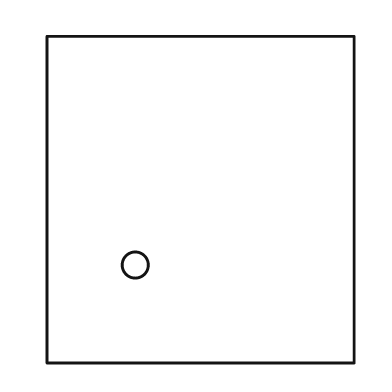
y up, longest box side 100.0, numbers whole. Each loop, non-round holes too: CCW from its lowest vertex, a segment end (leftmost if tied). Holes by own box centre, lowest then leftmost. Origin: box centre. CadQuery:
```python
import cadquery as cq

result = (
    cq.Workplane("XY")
    .moveTo(-47.0, -50.0)
    .lineTo(47.0, -50.0)
    .lineTo(47.0, 50.0)
    .lineTo(-47.0, 50.0)
    .close()
    .moveTo(-20.0, -20.0)
    .circle(4.0)
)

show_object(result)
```